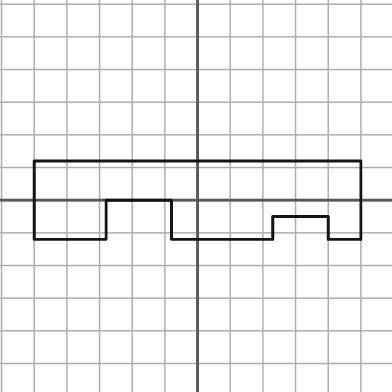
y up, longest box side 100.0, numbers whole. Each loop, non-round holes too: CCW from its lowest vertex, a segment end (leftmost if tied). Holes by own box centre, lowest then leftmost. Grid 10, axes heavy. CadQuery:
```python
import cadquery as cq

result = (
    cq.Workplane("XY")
    .moveTo(-50.0, -12.0)
    .lineTo(-28.0, -12.0)
    .lineTo(-28.0, 0.0)
    .lineTo(-8.0, 0.0)
    .lineTo(-8.0, -12.0)
    .lineTo(23.0, -12.0)
    .lineTo(23.0, -5.0)
    .lineTo(40.0, -5.0)
    .lineTo(40.0, -12.0)
    .lineTo(50.0, -12.0)
    .lineTo(50.0, 12.0)
    .lineTo(-50.0, 12.0)
    .close()
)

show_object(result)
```